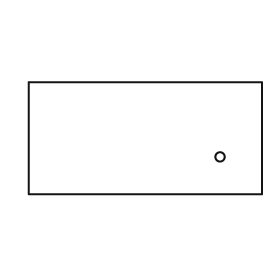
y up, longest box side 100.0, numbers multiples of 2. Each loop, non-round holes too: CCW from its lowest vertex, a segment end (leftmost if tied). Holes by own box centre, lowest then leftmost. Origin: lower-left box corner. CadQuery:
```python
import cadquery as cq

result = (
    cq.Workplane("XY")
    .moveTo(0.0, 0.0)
    .lineTo(100.0, 0.0)
    .lineTo(100.0, 48.0)
    .lineTo(0.0, 48.0)
    .close()
    .moveTo(82.0, 16.0)
    .circle(2.0)
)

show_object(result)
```